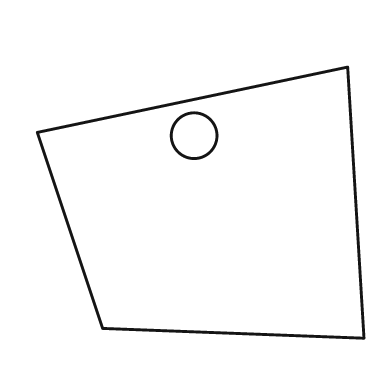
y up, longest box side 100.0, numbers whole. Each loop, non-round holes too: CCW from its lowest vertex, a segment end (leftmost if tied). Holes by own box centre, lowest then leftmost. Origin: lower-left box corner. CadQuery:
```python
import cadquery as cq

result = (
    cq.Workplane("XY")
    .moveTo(100.0, 0.0)
    .lineTo(95.0, 83.0)
    .lineTo(0.0, 63.0)
    .lineTo(20.0, 3.0)
    .close()
    .moveTo(48.0, 62.0)
    .circle(7.0)
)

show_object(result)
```